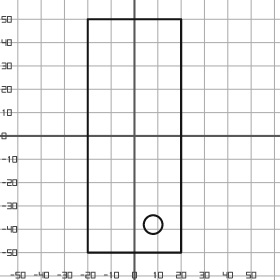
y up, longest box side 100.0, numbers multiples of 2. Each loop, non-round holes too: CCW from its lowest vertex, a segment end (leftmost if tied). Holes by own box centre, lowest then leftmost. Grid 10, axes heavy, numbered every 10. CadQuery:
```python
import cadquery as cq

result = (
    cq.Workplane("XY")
    .moveTo(-20.0, -50.0)
    .lineTo(20.0, -50.0)
    .lineTo(20.0, 50.0)
    .lineTo(-20.0, 50.0)
    .close()
    .moveTo(8.0, -38.0)
    .circle(4.0)
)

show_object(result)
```